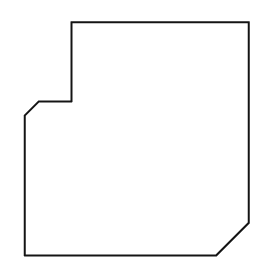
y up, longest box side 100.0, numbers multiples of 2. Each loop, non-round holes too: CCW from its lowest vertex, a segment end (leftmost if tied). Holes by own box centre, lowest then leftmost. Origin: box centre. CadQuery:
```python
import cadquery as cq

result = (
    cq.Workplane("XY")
    .moveTo(-48.0, -50.0)
    .lineTo(34.0, -50.0)
    .lineTo(48.0, -36.0)
    .lineTo(48.0, 50.0)
    .lineTo(-28.0, 50.0)
    .lineTo(-28.0, 16.0)
    .lineTo(-42.0, 16.0)
    .lineTo(-48.0, 10.0)
    .close()
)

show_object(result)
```